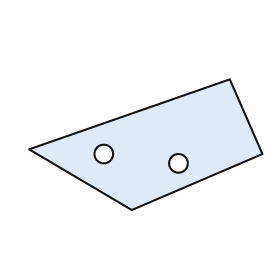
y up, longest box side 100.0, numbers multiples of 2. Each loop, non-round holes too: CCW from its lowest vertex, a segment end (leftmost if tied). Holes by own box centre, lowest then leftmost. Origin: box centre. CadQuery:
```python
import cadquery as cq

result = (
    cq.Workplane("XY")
    .moveTo(-6.0, -28.0)
    .lineTo(50.0, -4.0)
    .lineTo(36.0, 28.0)
    .lineTo(-50.0, -2.0)
    .close()
    .moveTo(14.0, -8.0)
    .circle(4.0)
    .moveTo(-18.0, -4.0)
    .circle(4.0)
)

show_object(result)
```